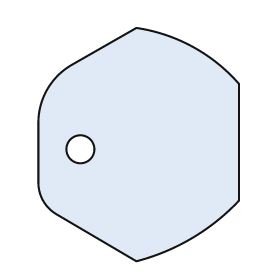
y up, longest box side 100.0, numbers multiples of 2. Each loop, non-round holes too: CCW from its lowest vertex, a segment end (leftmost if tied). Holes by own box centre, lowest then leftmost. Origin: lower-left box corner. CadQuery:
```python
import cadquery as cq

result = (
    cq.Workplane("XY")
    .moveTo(42.0, 0.0)
    .threePointArc((66.0, 10.0), (86.0, 26.0))
    .lineTo(86.0, 76.0)
    .threePointArc((66.0, 92.0), (42.0, 100.0))
    .lineTo(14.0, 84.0)
    .threePointArc((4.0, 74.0), (0.0, 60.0))
    .lineTo(0.0, 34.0)
    .threePointArc((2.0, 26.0), (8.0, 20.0))
    .close()
    .moveTo(18.0, 48.0)
    .circle(6.0)
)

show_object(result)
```